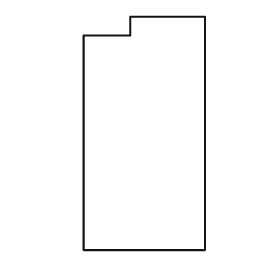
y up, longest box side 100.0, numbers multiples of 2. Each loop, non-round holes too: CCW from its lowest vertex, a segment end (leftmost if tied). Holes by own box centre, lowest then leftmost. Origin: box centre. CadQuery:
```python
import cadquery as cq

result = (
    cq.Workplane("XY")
    .moveTo(-26.0, -50.0)
    .lineTo(26.0, -50.0)
    .lineTo(26.0, 50.0)
    .lineTo(-6.0, 50.0)
    .lineTo(-6.0, 42.0)
    .lineTo(-26.0, 42.0)
    .close()
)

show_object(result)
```